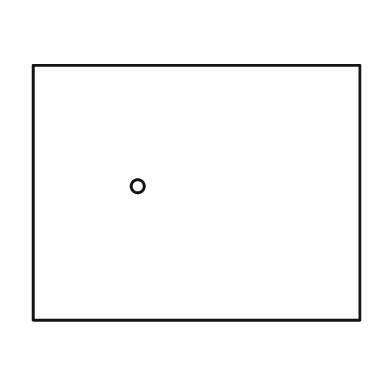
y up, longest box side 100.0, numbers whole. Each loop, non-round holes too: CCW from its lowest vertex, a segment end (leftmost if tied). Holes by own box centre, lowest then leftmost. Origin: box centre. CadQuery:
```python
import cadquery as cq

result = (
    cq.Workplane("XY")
    .moveTo(-50.0, -39.0)
    .lineTo(50.0, -39.0)
    .lineTo(50.0, 39.0)
    .lineTo(-50.0, 39.0)
    .close()
    .moveTo(-18.0, 2.0)
    .circle(2.0)
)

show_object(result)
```